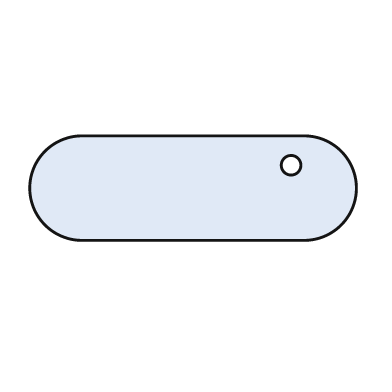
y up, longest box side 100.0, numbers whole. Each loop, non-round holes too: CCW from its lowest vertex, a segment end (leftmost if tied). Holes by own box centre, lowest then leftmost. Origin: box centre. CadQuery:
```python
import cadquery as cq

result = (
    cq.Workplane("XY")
    .moveTo(-34.0, -16.0)
    .lineTo(34.0, -16.0)
    .threePointArc((50.0, 0.0), (34.0, 16.0))
    .lineTo(-34.0, 16.0)
    .threePointArc((-50.0, 0.0), (-34.0, -16.0))
    .close()
    .moveTo(30.0, 7.0)
    .circle(3.0)
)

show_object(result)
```